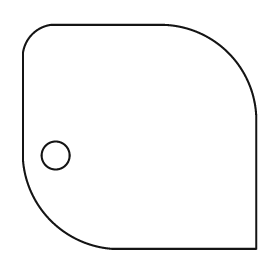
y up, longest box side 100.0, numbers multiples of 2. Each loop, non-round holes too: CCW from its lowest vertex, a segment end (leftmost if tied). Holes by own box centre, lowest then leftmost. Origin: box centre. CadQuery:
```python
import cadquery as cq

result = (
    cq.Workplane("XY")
    .moveTo(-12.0, -48.0)
    .lineTo(50.0, -48.0)
    .lineTo(50.0, 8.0)
    .threePointArc((38.0, 36.0), (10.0, 48.0))
    .lineTo(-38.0, 48.0)
    .threePointArc((-46.0, 44.0), (-50.0, 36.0))
    .lineTo(-50.0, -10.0)
    .threePointArc((-38.0, -36.0), (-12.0, -48.0))
    .close()
    .moveTo(-36.0, -8.0)
    .circle(6.0)
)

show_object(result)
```